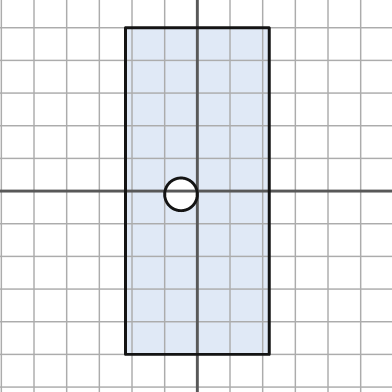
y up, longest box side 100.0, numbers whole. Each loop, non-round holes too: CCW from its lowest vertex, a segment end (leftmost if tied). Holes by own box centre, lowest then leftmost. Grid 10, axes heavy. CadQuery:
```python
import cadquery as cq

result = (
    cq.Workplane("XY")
    .moveTo(-22.0, -50.0)
    .lineTo(22.0, -50.0)
    .lineTo(22.0, 50.0)
    .lineTo(-22.0, 50.0)
    .close()
    .moveTo(-5.0, -1.0)
    .circle(5.0)
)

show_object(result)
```